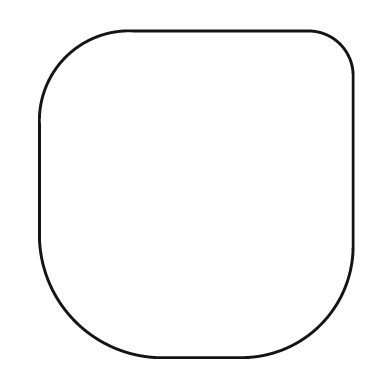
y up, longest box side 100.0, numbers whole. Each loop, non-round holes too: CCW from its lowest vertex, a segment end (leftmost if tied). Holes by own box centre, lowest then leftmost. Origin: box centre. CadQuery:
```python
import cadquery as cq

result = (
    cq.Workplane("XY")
    .moveTo(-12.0, -50.0)
    .lineTo(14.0, -50.0)
    .threePointArc((38.0, -40.0), (48.0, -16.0))
    .lineTo(48.0, 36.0)
    .threePointArc((44.0, 46.0), (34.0, 50.0))
    .lineTo(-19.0, 50.0)
    .threePointArc((-40.0, 42.0), (-48.0, 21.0))
    .lineTo(-48.0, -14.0)
    .threePointArc((-37.0, -39.0), (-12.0, -50.0))
    .close()
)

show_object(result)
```